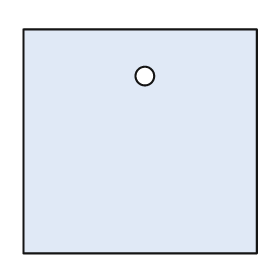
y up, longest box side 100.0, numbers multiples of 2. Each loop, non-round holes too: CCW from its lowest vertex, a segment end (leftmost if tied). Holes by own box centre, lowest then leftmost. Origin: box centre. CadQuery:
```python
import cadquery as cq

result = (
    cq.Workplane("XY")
    .moveTo(-50.0, -48.0)
    .lineTo(50.0, -48.0)
    .lineTo(50.0, 48.0)
    .lineTo(-50.0, 48.0)
    .close()
    .moveTo(2.0, 28.0)
    .circle(4.0)
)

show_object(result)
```